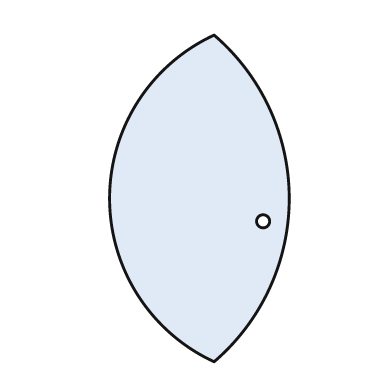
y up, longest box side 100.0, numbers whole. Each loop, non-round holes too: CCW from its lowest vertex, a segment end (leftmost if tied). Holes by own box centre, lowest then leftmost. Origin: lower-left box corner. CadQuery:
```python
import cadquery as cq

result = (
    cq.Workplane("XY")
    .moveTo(32.0, 0.0)
    .threePointArc((55.0, 50.0), (32.0, 100.0))
    .threePointArc((0.0, 50.0), (32.0, 0.0))
    .close()
    .moveTo(47.0, 43.0)
    .circle(2.0)
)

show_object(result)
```